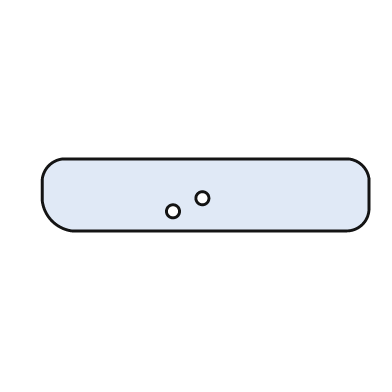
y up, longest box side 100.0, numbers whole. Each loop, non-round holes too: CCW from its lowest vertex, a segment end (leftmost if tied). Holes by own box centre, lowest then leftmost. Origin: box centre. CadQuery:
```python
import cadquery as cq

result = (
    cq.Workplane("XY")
    .moveTo(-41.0, -11.0)
    .lineTo(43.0, -11.0)
    .threePointArc((48.0, -9.0), (50.0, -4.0))
    .lineTo(50.0, 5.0)
    .threePointArc((48.0, 9.0), (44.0, 11.0))
    .lineTo(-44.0, 11.0)
    .threePointArc((-48.0, 9.0), (-50.0, 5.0))
    .lineTo(-50.0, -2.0)
    .threePointArc((-47.0, -8.0), (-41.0, -11.0))
    .close()
    .moveTo(-10.0, -5.0)
    .circle(2.0)
    .moveTo(-1.0, -1.0)
    .circle(2.0)
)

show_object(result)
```